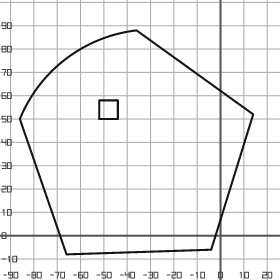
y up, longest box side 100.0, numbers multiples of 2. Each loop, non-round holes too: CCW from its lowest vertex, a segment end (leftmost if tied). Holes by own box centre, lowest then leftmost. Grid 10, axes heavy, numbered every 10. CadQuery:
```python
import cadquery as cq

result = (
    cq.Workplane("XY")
    .moveTo(-66.0, -8.0)
    .lineTo(-4.0, -6.0)
    .lineTo(14.0, 52.0)
    .lineTo(-36.0, 88.0)
    .threePointArc((-66.0, 76.0), (-86.0, 50.0))
    .close()
    .moveTo(-52.0, 50.0)
    .lineTo(-44.0, 50.0)
    .lineTo(-44.0, 58.0)
    .lineTo(-52.0, 58.0)
    .close()
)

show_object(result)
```